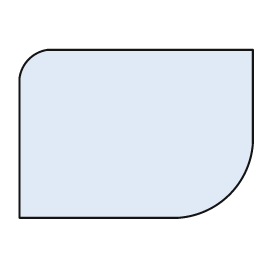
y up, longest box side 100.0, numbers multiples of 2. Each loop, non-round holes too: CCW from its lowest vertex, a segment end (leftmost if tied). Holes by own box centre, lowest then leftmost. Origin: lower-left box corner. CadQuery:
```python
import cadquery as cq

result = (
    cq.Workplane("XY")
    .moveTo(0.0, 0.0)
    .lineTo(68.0, 0.0)
    .threePointArc((90.0, 10.0), (100.0, 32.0))
    .lineTo(100.0, 72.0)
    .lineTo(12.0, 72.0)
    .threePointArc((4.0, 68.0), (0.0, 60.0))
    .close()
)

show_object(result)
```